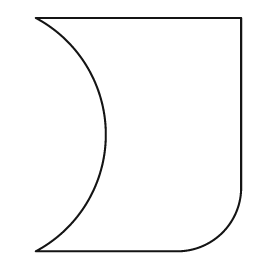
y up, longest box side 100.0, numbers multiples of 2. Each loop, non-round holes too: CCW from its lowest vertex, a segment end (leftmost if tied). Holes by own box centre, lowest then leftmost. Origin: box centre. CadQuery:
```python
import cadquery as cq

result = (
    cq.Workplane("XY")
    .moveTo(-44.0, -50.0)
    .lineTo(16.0, -50.0)
    .threePointArc((36.0, -42.0), (44.0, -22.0))
    .lineTo(44.0, 50.0)
    .lineTo(-44.0, 50.0)
    .threePointArc((-14.0, 0.0), (-44.0, -50.0))
    .close()
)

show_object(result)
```